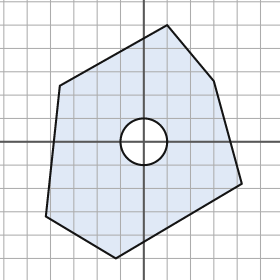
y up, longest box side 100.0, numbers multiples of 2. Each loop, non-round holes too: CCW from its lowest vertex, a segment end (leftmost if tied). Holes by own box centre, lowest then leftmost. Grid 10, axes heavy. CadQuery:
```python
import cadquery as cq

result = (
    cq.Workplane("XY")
    .moveTo(-12.0, -50.0)
    .lineTo(42.0, -18.0)
    .lineTo(30.0, 26.0)
    .lineTo(10.0, 50.0)
    .lineTo(-36.0, 24.0)
    .lineTo(-42.0, -32.0)
    .close()
    .moveTo(0.0, 0.0)
    .circle(10.0)
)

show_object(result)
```